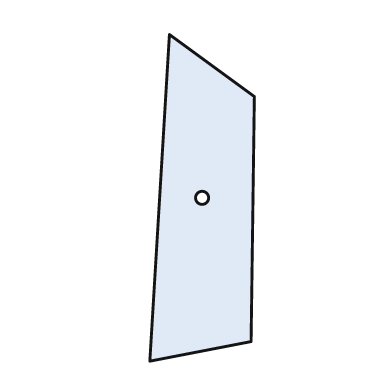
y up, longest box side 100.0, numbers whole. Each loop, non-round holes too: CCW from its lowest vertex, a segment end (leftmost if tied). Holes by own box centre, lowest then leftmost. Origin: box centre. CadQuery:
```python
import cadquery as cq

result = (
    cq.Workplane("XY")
    .moveTo(-16.0, -50.0)
    .lineTo(15.0, -44.0)
    .lineTo(16.0, 31.0)
    .lineTo(-10.0, 50.0)
    .close()
    .moveTo(0.0, 0.0)
    .circle(2.0)
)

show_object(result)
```